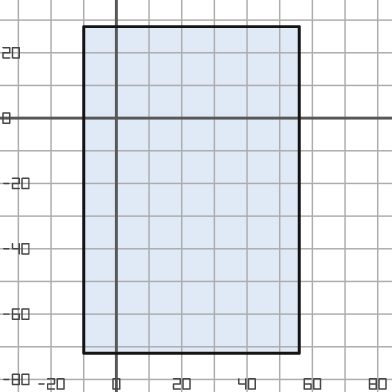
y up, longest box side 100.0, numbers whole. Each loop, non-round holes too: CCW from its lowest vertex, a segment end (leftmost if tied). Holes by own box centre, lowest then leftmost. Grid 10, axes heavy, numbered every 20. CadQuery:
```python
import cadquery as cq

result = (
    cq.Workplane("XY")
    .moveTo(-10.0, -72.0)
    .lineTo(56.0, -72.0)
    .lineTo(56.0, 28.0)
    .lineTo(-10.0, 28.0)
    .close()
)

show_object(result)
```